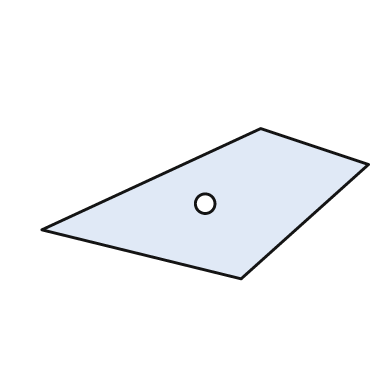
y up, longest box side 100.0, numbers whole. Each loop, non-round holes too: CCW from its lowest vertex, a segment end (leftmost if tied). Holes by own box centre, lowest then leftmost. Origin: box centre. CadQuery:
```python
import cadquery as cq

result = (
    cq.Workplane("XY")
    .moveTo(11.0, -23.0)
    .lineTo(50.0, 12.0)
    .lineTo(17.0, 23.0)
    .lineTo(-50.0, -8.0)
    .close()
    .moveTo(0.0, 0.0)
    .circle(3.0)
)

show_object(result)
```